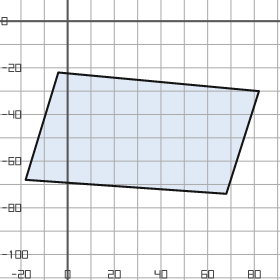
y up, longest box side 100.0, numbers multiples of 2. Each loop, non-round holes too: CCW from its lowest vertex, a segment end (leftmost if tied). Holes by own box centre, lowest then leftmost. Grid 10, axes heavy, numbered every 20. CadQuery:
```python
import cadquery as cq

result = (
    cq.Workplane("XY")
    .moveTo(68.0, -74.0)
    .lineTo(82.0, -30.0)
    .lineTo(-4.0, -22.0)
    .lineTo(-18.0, -68.0)
    .close()
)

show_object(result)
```